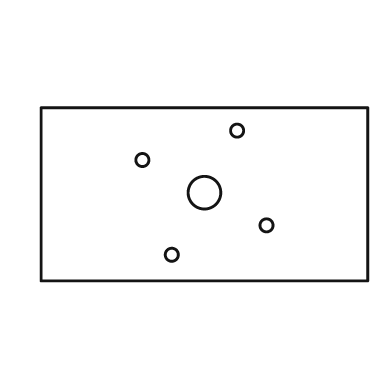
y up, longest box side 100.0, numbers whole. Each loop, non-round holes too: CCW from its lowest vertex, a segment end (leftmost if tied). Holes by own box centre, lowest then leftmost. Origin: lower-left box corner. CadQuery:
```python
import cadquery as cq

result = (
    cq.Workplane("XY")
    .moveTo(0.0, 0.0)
    .lineTo(100.0, 0.0)
    .lineTo(100.0, 53.0)
    .lineTo(0.0, 53.0)
    .close()
    .moveTo(40.0, 8.0)
    .circle(2.0)
    .moveTo(69.0, 17.0)
    .circle(2.0)
    .moveTo(50.0, 27.0)
    .circle(5.0)
    .moveTo(31.0, 37.0)
    .circle(2.0)
    .moveTo(60.0, 46.0)
    .circle(2.0)
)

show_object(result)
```